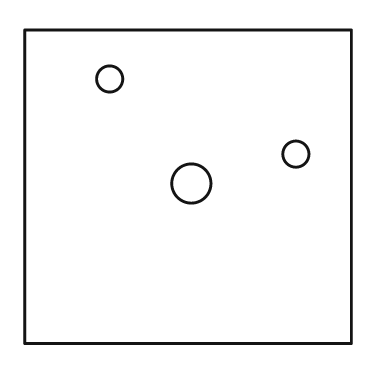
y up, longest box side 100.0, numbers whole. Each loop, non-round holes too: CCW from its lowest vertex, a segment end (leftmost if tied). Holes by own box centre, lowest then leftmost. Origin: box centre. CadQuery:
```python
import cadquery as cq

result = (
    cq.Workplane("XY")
    .moveTo(-50.0, -48.0)
    .lineTo(50.0, -48.0)
    .lineTo(50.0, 48.0)
    .lineTo(-50.0, 48.0)
    .close()
    .moveTo(1.0, 1.0)
    .circle(6.0)
    .moveTo(33.0, 10.0)
    .circle(4.0)
    .moveTo(-24.0, 33.0)
    .circle(4.0)
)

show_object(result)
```